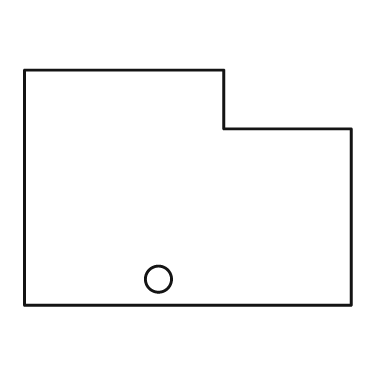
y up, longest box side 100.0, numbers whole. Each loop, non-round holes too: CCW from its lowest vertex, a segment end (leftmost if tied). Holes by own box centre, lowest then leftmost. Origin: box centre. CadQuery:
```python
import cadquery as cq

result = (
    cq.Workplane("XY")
    .moveTo(-50.0, -36.0)
    .lineTo(50.0, -36.0)
    .lineTo(50.0, 18.0)
    .lineTo(11.0, 18.0)
    .lineTo(11.0, 36.0)
    .lineTo(-50.0, 36.0)
    .close()
    .moveTo(-9.0, -28.0)
    .circle(4.0)
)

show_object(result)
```